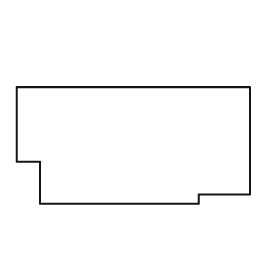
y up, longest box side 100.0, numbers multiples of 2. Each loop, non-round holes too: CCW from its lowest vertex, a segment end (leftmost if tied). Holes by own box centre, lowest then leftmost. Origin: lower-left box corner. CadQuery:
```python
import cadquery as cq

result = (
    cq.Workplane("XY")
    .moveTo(10.0, 0.0)
    .lineTo(78.0, 0.0)
    .lineTo(78.0, 4.0)
    .lineTo(100.0, 4.0)
    .lineTo(100.0, 50.0)
    .lineTo(0.0, 50.0)
    .lineTo(0.0, 18.0)
    .lineTo(10.0, 18.0)
    .close()
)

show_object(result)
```